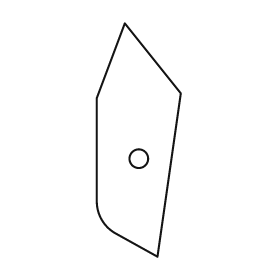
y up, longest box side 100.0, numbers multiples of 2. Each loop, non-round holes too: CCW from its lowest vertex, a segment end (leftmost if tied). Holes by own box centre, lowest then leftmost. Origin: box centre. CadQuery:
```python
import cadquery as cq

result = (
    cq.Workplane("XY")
    .moveTo(8.0, -50.0)
    .lineTo(18.0, 20.0)
    .lineTo(-6.0, 50.0)
    .lineTo(-18.0, 18.0)
    .lineTo(-18.0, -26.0)
    .threePointArc((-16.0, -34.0), (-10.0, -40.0))
    .close()
    .moveTo(0.0, -8.0)
    .circle(4.0)
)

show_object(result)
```